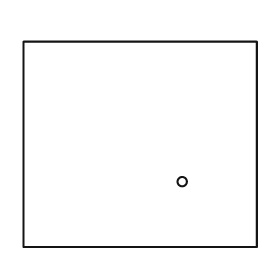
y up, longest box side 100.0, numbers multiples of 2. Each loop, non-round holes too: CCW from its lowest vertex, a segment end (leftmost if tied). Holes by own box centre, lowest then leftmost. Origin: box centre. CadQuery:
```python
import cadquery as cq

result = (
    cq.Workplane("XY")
    .moveTo(-50.0, -44.0)
    .lineTo(50.0, -44.0)
    .lineTo(50.0, 44.0)
    .lineTo(-50.0, 44.0)
    .close()
    .moveTo(18.0, -16.0)
    .circle(2.0)
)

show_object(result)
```